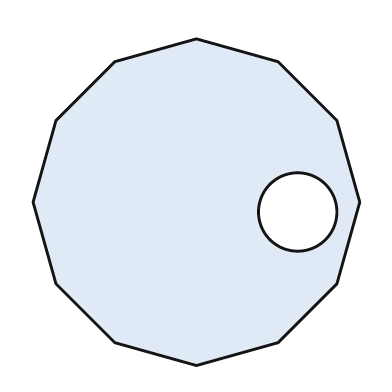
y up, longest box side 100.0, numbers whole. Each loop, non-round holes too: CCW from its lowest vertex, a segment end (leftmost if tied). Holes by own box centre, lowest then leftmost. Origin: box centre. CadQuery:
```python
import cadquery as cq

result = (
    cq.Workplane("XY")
    .moveTo(0.0, -50.0)
    .lineTo(25.0, -43.0)
    .lineTo(43.0, -25.0)
    .lineTo(50.0, 0.0)
    .lineTo(43.0, 25.0)
    .lineTo(25.0, 43.0)
    .lineTo(0.0, 50.0)
    .lineTo(-25.0, 43.0)
    .lineTo(-43.0, 25.0)
    .lineTo(-50.0, 0.0)
    .lineTo(-43.0, -25.0)
    .lineTo(-25.0, -43.0)
    .close()
    .moveTo(31.0, -3.0)
    .circle(12.0)
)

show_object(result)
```